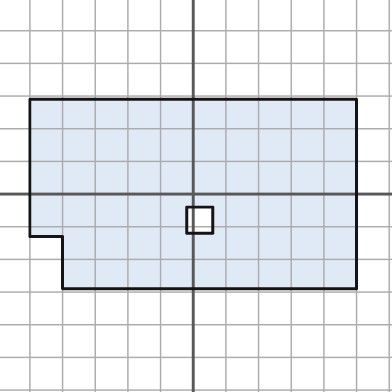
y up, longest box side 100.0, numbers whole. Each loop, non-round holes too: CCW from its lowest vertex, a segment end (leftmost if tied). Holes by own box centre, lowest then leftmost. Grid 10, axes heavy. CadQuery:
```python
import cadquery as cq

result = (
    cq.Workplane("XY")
    .moveTo(-40.0, -29.0)
    .lineTo(50.0, -29.0)
    .lineTo(50.0, 29.0)
    .lineTo(-50.0, 29.0)
    .lineTo(-50.0, -13.0)
    .lineTo(-40.0, -13.0)
    .close()
    .moveTo(-2.0, -12.0)
    .lineTo(6.0, -12.0)
    .lineTo(6.0, -4.0)
    .lineTo(-2.0, -4.0)
    .close()
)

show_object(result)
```